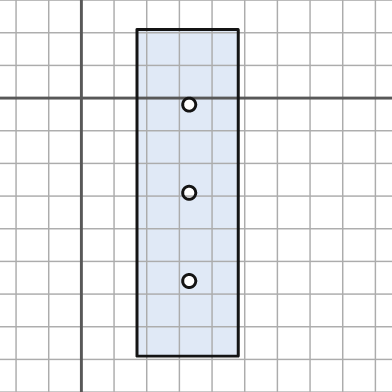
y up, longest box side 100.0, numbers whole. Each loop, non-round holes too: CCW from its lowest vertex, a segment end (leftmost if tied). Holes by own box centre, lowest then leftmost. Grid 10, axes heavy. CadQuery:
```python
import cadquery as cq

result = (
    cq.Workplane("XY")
    .moveTo(17.0, -79.0)
    .lineTo(48.0, -79.0)
    .lineTo(48.0, 21.0)
    .lineTo(17.0, 21.0)
    .close()
    .moveTo(33.0, -56.0)
    .circle(2.0)
    .moveTo(33.0, -29.0)
    .circle(2.0)
    .moveTo(33.0, -2.0)
    .circle(2.0)
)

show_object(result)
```